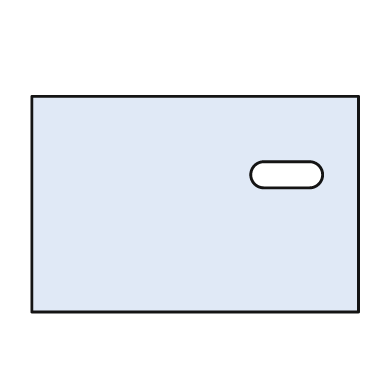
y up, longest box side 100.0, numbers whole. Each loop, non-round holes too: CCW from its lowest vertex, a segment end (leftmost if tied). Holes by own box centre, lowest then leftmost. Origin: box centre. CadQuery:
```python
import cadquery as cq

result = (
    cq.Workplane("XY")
    .moveTo(-50.0, -33.0)
    .lineTo(50.0, -33.0)
    .lineTo(50.0, 33.0)
    .lineTo(-50.0, 33.0)
    .close()
    .moveTo(21.0, 5.0)
    .lineTo(35.0, 5.0)
    .threePointArc((39.0, 9.0), (35.0, 13.0))
    .lineTo(21.0, 13.0)
    .threePointArc((17.0, 9.0), (21.0, 5.0))
    .close()
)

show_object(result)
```